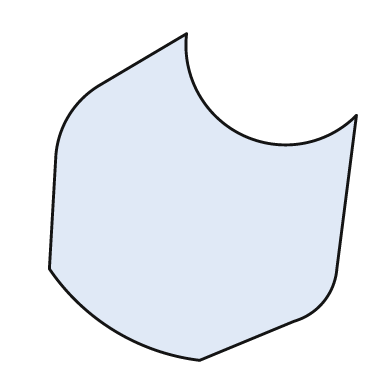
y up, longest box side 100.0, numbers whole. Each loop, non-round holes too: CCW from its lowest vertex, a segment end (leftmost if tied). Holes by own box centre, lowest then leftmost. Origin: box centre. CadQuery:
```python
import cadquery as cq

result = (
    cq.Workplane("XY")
    .moveTo(-1.0, -50.0)
    .lineTo(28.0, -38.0)
    .threePointArc((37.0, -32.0), (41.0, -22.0))
    .lineTo(47.0, 25.0)
    .threePointArc((12.0, 19.0), (-5.0, 50.0))
    .lineTo(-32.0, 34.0)
    .threePointArc((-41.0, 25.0), (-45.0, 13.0))
    .lineTo(-47.0, -22.0)
    .threePointArc((-27.0, -41.0), (-1.0, -50.0))
    .close()
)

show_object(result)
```